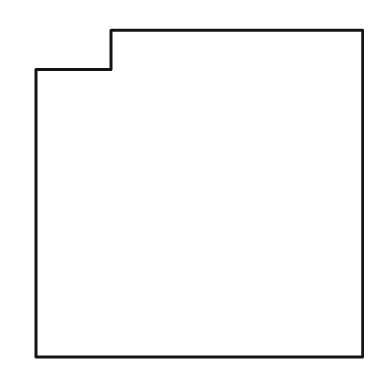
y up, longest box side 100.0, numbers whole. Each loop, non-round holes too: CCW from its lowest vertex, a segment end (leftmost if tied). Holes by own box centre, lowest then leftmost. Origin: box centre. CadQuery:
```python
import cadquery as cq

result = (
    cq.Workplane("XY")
    .moveTo(-50.0, -50.0)
    .lineTo(50.0, -50.0)
    .lineTo(50.0, 50.0)
    .lineTo(-27.0, 50.0)
    .lineTo(-27.0, 38.0)
    .lineTo(-50.0, 38.0)
    .close()
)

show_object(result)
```